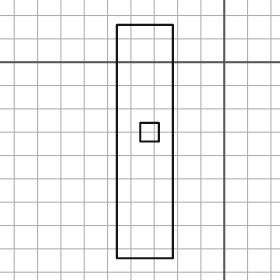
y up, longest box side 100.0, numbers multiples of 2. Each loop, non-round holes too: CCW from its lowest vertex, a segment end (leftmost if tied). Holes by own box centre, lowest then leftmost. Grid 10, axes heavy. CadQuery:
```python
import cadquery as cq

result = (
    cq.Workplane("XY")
    .moveTo(-46.0, -84.0)
    .lineTo(-22.0, -84.0)
    .lineTo(-22.0, 16.0)
    .lineTo(-46.0, 16.0)
    .close()
    .moveTo(-36.0, -34.0)
    .lineTo(-28.0, -34.0)
    .lineTo(-28.0, -26.0)
    .lineTo(-36.0, -26.0)
    .close()
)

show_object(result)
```